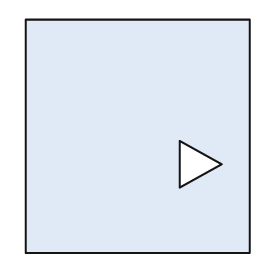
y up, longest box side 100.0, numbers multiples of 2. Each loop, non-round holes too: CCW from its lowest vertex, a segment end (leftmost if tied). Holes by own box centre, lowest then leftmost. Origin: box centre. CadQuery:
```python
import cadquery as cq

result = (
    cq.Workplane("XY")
    .moveTo(-48.0, -50.0)
    .lineTo(48.0, -50.0)
    .lineTo(48.0, 50.0)
    .lineTo(-48.0, 50.0)
    .close()
    .moveTo(18.0, -22.0)
    .lineTo(36.0, -12.0)
    .lineTo(18.0, -2.0)
    .close()
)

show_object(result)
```